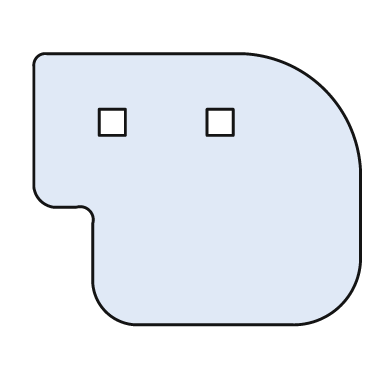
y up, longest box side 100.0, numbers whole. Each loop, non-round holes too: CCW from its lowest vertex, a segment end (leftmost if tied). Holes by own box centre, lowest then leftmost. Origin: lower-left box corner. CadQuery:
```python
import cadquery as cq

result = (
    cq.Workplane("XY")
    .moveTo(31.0, 0.0)
    .lineTo(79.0, 0.0)
    .threePointArc((94.0, 6.0), (100.0, 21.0))
    .lineTo(100.0, 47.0)
    .threePointArc((89.0, 72.0), (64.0, 83.0))
    .lineTo(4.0, 83.0)
    .threePointArc((1.0, 82.0), (0.0, 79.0))
    .lineTo(0.0, 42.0)
    .threePointArc((2.0, 38.0), (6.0, 36.0))
    .lineTo(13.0, 36.0)
    .threePointArc((17.0, 35.0), (18.0, 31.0))
    .lineTo(18.0, 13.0)
    .threePointArc((22.0, 4.0), (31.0, 0.0))
    .close()
    .moveTo(20.0, 58.0)
    .lineTo(28.0, 58.0)
    .lineTo(28.0, 66.0)
    .lineTo(20.0, 66.0)
    .close()
    .moveTo(53.0, 58.0)
    .lineTo(61.0, 58.0)
    .lineTo(61.0, 66.0)
    .lineTo(53.0, 66.0)
    .close()
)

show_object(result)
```